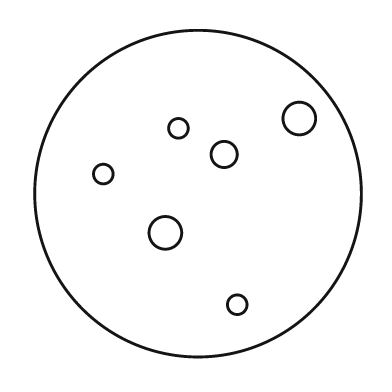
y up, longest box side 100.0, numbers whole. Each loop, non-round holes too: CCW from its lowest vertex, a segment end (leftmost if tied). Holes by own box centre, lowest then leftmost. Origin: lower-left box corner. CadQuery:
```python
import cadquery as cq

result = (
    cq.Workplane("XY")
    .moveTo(50.0, 50.0)
    .circle(50.0)
    .moveTo(62.0, 16.0)
    .circle(3.0)
    .moveTo(40.0, 38.0)
    .circle(5.0)
    .moveTo(21.0, 56.0)
    .circle(3.0)
    .moveTo(58.0, 62.0)
    .circle(4.0)
    .moveTo(44.0, 70.0)
    .circle(3.0)
    .moveTo(81.0, 73.0)
    .circle(5.0)
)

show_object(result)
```